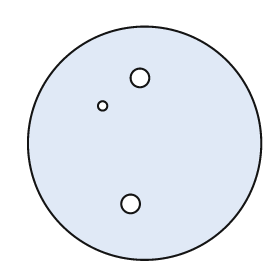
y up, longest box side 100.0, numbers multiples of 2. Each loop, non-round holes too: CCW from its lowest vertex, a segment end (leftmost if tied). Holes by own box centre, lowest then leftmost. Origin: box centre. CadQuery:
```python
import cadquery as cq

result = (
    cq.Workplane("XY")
    .moveTo(0.0, 0.0)
    .circle(50.0)
    .moveTo(-6.0, -26.0)
    .circle(4.0)
    .moveTo(-18.0, 16.0)
    .circle(2.0)
    .moveTo(-2.0, 28.0)
    .circle(4.0)
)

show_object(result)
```